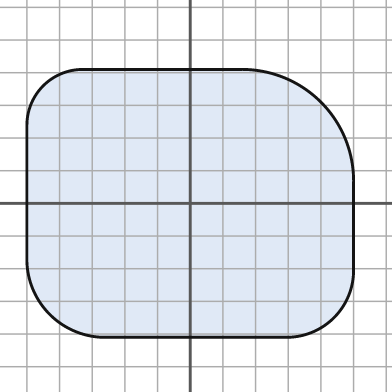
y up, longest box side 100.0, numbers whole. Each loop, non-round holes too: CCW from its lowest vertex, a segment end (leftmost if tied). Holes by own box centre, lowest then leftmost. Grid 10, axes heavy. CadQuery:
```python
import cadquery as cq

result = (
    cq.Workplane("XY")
    .moveTo(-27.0, -41.0)
    .lineTo(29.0, -41.0)
    .threePointArc((44.0, -35.0), (50.0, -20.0))
    .lineTo(50.0, 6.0)
    .threePointArc((40.0, 31.0), (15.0, 41.0))
    .lineTo(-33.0, 41.0)
    .threePointArc((-45.0, 36.0), (-50.0, 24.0))
    .lineTo(-50.0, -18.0)
    .threePointArc((-43.0, -34.0), (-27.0, -41.0))
    .close()
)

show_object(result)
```